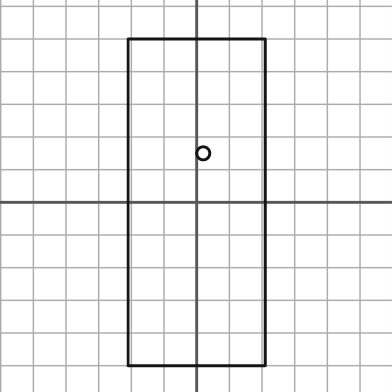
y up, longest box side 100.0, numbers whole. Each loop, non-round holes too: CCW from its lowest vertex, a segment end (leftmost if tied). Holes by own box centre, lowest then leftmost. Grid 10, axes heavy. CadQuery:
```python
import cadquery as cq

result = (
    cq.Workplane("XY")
    .moveTo(-21.0, -50.0)
    .lineTo(21.0, -50.0)
    .lineTo(21.0, 50.0)
    .lineTo(-21.0, 50.0)
    .close()
    .moveTo(2.0, 15.0)
    .circle(2.0)
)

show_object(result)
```